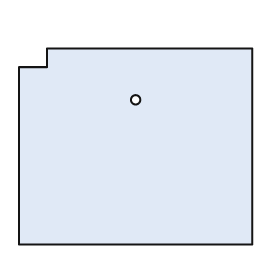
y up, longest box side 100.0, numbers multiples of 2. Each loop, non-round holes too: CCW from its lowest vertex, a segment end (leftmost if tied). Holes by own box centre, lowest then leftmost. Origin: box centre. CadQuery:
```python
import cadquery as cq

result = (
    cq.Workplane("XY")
    .moveTo(-50.0, -42.0)
    .lineTo(50.0, -42.0)
    .lineTo(50.0, 42.0)
    .lineTo(-38.0, 42.0)
    .lineTo(-38.0, 34.0)
    .lineTo(-50.0, 34.0)
    .close()
    .moveTo(0.0, 20.0)
    .circle(2.0)
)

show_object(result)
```